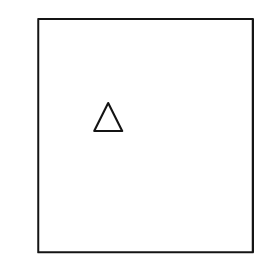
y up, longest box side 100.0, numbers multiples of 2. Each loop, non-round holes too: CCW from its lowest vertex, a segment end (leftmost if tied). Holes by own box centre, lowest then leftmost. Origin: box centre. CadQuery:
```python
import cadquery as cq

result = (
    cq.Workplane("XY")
    .moveTo(-46.0, -50.0)
    .lineTo(46.0, -50.0)
    .lineTo(46.0, 50.0)
    .lineTo(-46.0, 50.0)
    .close()
    .moveTo(-22.0, 2.0)
    .lineTo(-10.0, 2.0)
    .lineTo(-16.0, 14.0)
    .close()
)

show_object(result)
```